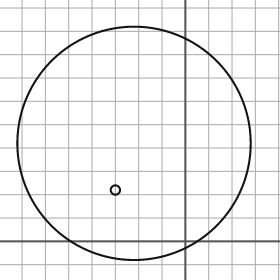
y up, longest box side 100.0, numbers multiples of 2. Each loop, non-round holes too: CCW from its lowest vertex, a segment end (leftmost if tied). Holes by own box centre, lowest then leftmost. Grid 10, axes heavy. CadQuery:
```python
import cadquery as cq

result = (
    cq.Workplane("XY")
    .moveTo(-22.0, 42.0)
    .circle(50.0)
    .moveTo(-30.0, 22.0)
    .circle(2.0)
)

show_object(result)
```